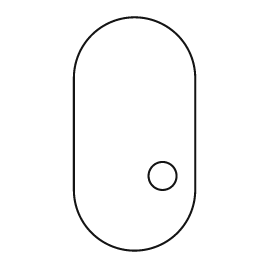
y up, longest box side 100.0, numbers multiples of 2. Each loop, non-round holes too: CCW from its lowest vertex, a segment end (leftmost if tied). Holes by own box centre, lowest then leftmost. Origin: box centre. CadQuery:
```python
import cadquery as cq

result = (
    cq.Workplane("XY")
    .moveTo(-26.0, -24.0)
    .threePointArc((0.0, -50.0), (26.0, -24.0))
    .lineTo(26.0, 24.0)
    .threePointArc((0.0, 50.0), (-26.0, 24.0))
    .close()
    .moveTo(12.0, -18.0)
    .circle(6.0)
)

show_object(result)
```